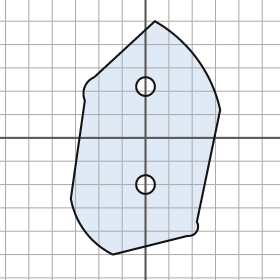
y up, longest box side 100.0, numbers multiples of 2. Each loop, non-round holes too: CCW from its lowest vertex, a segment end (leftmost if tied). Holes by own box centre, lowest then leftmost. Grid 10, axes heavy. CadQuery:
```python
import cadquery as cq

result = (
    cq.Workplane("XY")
    .moveTo(-14.0, -50.0)
    .lineTo(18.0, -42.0)
    .threePointArc((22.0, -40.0), (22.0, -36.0))
    .lineTo(32.0, 12.0)
    .threePointArc((22.0, 34.0), (4.0, 50.0))
    .lineTo(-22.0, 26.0)
    .threePointArc((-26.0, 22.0), (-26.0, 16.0))
    .lineTo(-32.0, -26.0)
    .threePointArc((-26.0, -40.0), (-14.0, -50.0))
    .close()
    .moveTo(0.0, -20.0)
    .circle(4.0)
    .moveTo(0.0, 22.0)
    .circle(4.0)
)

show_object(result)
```